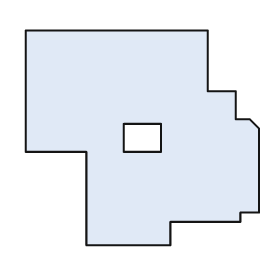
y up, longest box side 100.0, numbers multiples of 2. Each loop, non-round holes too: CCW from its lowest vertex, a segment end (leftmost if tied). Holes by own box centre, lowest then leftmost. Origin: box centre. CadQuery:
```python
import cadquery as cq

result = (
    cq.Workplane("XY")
    .moveTo(-24.0, -46.0)
    .lineTo(12.0, -46.0)
    .lineTo(12.0, -36.0)
    .lineTo(42.0, -36.0)
    .lineTo(42.0, -32.0)
    .lineTo(50.0, -32.0)
    .lineTo(50.0, 4.0)
    .lineTo(46.0, 8.0)
    .lineTo(40.0, 8.0)
    .lineTo(40.0, 20.0)
    .lineTo(28.0, 20.0)
    .lineTo(28.0, 46.0)
    .lineTo(-50.0, 46.0)
    .lineTo(-50.0, -6.0)
    .lineTo(-24.0, -6.0)
    .close()
    .moveTo(-8.0, -6.0)
    .lineTo(8.0, -6.0)
    .lineTo(8.0, 6.0)
    .lineTo(-8.0, 6.0)
    .close()
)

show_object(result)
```